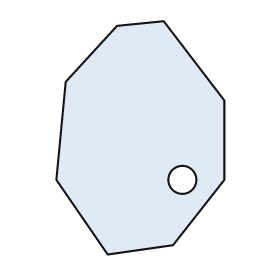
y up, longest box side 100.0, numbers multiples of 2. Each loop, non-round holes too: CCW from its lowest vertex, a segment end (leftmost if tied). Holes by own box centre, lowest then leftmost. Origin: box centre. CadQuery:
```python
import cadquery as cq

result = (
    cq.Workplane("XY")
    .moveTo(-14.0, -50.0)
    .lineTo(14.0, -46.0)
    .lineTo(36.0, -18.0)
    .lineTo(36.0, 16.0)
    .lineTo(10.0, 50.0)
    .lineTo(-10.0, 48.0)
    .lineTo(-32.0, 24.0)
    .lineTo(-36.0, -18.0)
    .close()
    .moveTo(18.0, -18.0)
    .circle(6.0)
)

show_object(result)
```